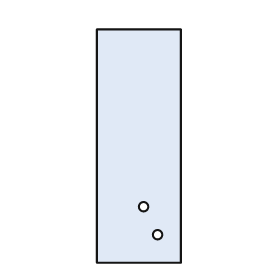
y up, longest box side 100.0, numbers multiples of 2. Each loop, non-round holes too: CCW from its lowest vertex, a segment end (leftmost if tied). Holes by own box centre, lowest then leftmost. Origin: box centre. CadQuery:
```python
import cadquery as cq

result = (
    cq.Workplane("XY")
    .moveTo(-18.0, -50.0)
    .lineTo(18.0, -50.0)
    .lineTo(18.0, 50.0)
    .lineTo(-18.0, 50.0)
    .close()
    .moveTo(8.0, -38.0)
    .circle(2.0)
    .moveTo(2.0, -26.0)
    .circle(2.0)
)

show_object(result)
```